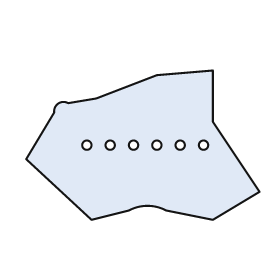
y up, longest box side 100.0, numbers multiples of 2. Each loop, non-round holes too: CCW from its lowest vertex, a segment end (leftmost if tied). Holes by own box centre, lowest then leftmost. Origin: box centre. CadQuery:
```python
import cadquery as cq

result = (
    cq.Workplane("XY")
    .moveTo(-22.0, -32.0)
    .lineTo(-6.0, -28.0)
    .threePointArc((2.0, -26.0), (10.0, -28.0))
    .lineTo(30.0, -32.0)
    .lineTo(50.0, -20.0)
    .lineTo(30.0, 10.0)
    .lineTo(30.0, 32.0)
    .lineTo(6.0, 30.0)
    .lineTo(-20.0, 20.0)
    .lineTo(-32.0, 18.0)
    .threePointArc((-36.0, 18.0), (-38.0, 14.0))
    .lineTo(-50.0, -6.0)
    .close()
    .moveTo(-24.0, 0.0)
    .circle(2.0)
    .moveTo(-14.0, 0.0)
    .circle(2.0)
    .moveTo(-4.0, 0.0)
    .circle(2.0)
    .moveTo(6.0, 0.0)
    .circle(2.0)
    .moveTo(16.0, 0.0)
    .circle(2.0)
    .moveTo(26.0, 0.0)
    .circle(2.0)
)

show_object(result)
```